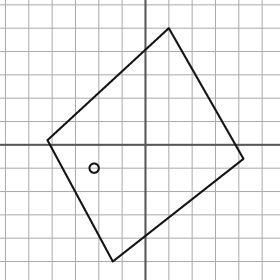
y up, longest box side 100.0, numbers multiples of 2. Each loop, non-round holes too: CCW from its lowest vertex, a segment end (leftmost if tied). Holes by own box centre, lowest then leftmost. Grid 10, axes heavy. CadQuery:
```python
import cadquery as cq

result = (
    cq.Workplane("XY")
    .moveTo(-14.0, -50.0)
    .lineTo(42.0, -6.0)
    .lineTo(10.0, 50.0)
    .lineTo(-42.0, 2.0)
    .close()
    .moveTo(-22.0, -10.0)
    .circle(2.0)
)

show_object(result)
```